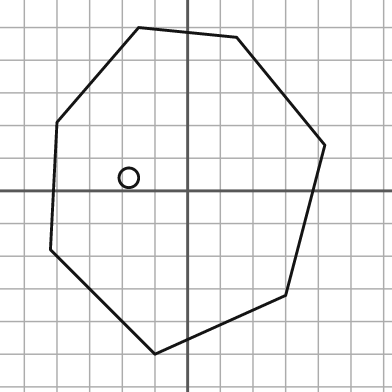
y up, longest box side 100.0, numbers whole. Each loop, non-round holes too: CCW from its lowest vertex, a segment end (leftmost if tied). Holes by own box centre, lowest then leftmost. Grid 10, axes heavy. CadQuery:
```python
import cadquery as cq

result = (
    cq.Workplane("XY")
    .moveTo(-10.0, -50.0)
    .lineTo(30.0, -32.0)
    .lineTo(42.0, 14.0)
    .lineTo(15.0, 47.0)
    .lineTo(-15.0, 50.0)
    .lineTo(-40.0, 21.0)
    .lineTo(-42.0, -18.0)
    .close()
    .moveTo(-18.0, 4.0)
    .circle(3.0)
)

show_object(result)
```